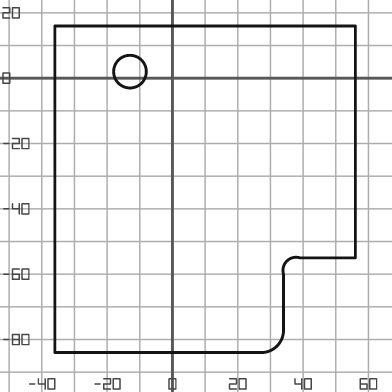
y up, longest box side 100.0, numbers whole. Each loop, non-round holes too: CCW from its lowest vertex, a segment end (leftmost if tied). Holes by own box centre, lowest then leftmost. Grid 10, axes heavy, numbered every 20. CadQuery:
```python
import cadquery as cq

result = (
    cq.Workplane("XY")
    .moveTo(-36.0, -84.0)
    .lineTo(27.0, -84.0)
    .threePointArc((32.0, -82.0), (34.0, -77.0))
    .lineTo(34.0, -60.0)
    .threePointArc((35.0, -56.0), (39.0, -55.0))
    .lineTo(56.0, -55.0)
    .lineTo(56.0, 16.0)
    .lineTo(-36.0, 16.0)
    .close()
    .moveTo(-13.0, 2.0)
    .circle(5.0)
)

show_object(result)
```